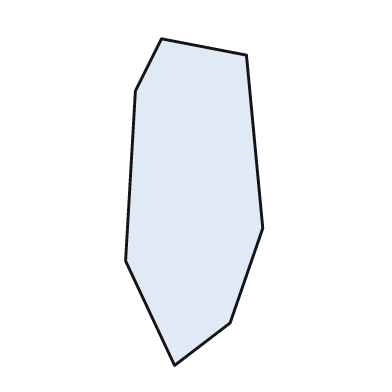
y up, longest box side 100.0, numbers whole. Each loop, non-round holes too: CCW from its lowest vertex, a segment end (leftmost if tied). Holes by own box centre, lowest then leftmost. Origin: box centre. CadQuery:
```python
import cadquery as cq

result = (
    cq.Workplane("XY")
    .moveTo(-6.0, -50.0)
    .lineTo(11.0, -37.0)
    .lineTo(21.0, -8.0)
    .lineTo(16.0, 45.0)
    .lineTo(-10.0, 50.0)
    .lineTo(-18.0, 34.0)
    .lineTo(-21.0, -18.0)
    .close()
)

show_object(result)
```